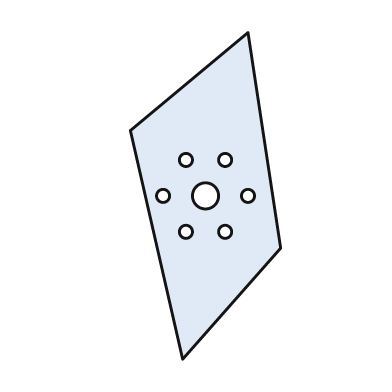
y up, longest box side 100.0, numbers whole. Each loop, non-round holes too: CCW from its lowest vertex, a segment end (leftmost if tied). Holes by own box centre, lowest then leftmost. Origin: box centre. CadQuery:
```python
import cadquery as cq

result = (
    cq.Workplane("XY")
    .moveTo(-7.0, -50.0)
    .lineTo(23.0, -16.0)
    .lineTo(13.0, 50.0)
    .lineTo(-23.0, 20.0)
    .close()
    .moveTo(-6.0, -11.0)
    .circle(2.0)
    .moveTo(6.0, -11.0)
    .circle(2.0)
    .moveTo(-13.0, 0.0)
    .circle(2.0)
    .moveTo(0.0, 0.0)
    .circle(4.0)
    .moveTo(13.0, 0.0)
    .circle(2.0)
    .moveTo(-6.0, 11.0)
    .circle(2.0)
    .moveTo(6.0, 11.0)
    .circle(2.0)
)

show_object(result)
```